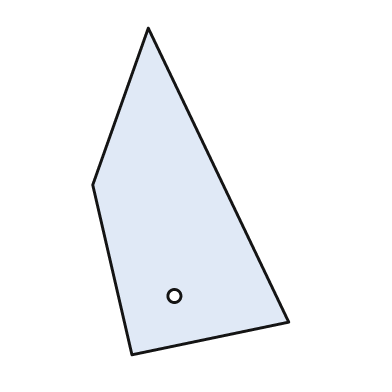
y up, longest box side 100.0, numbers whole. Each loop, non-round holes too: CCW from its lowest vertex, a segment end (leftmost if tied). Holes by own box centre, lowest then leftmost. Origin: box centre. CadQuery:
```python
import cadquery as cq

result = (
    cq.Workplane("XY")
    .moveTo(-18.0, -50.0)
    .lineTo(30.0, -40.0)
    .lineTo(-13.0, 50.0)
    .lineTo(-30.0, 2.0)
    .close()
    .moveTo(-5.0, -32.0)
    .circle(2.0)
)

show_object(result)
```